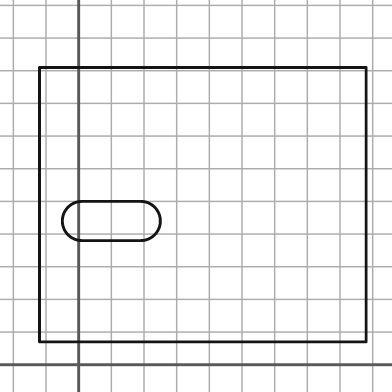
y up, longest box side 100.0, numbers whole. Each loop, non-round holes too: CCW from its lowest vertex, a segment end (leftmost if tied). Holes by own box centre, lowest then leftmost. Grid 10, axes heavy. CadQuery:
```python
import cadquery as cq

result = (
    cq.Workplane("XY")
    .moveTo(-12.0, 7.0)
    .lineTo(88.0, 7.0)
    .lineTo(88.0, 91.0)
    .lineTo(-12.0, 91.0)
    .close()
    .moveTo(1.0, 38.0)
    .lineTo(19.0, 38.0)
    .threePointArc((25.0, 44.0), (19.0, 50.0))
    .lineTo(1.0, 50.0)
    .threePointArc((-5.0, 44.0), (1.0, 38.0))
    .close()
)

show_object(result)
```